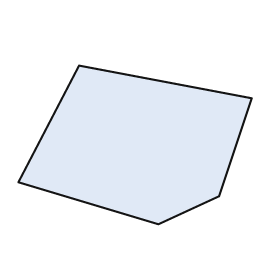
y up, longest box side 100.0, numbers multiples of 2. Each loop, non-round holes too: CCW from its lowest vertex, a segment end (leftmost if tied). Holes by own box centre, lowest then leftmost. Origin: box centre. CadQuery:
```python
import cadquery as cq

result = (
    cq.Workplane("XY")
    .moveTo(10.0, -34.0)
    .lineTo(36.0, -22.0)
    .lineTo(50.0, 20.0)
    .lineTo(-24.0, 34.0)
    .lineTo(-50.0, -16.0)
    .close()
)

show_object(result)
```